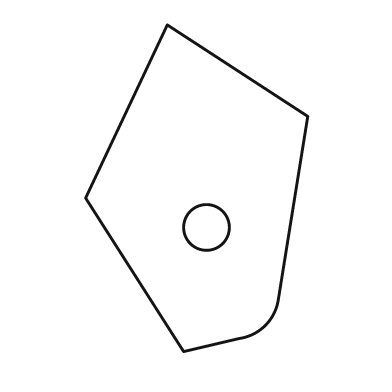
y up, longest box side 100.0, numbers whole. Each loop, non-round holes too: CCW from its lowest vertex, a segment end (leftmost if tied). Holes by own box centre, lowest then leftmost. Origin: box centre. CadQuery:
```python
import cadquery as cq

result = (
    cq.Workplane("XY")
    .moveTo(-4.0, -50.0)
    .lineTo(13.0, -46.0)
    .threePointArc((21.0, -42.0), (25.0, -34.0))
    .lineTo(34.0, 22.0)
    .lineTo(-9.0, 50.0)
    .lineTo(-34.0, -3.0)
    .close()
    .moveTo(3.0, -12.0)
    .circle(7.0)
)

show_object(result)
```